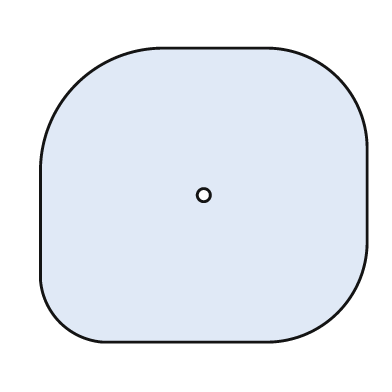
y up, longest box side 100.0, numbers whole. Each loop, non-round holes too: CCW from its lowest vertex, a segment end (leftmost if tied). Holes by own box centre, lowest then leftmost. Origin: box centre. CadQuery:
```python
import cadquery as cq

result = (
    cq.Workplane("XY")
    .moveTo(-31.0, -45.0)
    .lineTo(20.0, -45.0)
    .threePointArc((41.0, -36.0), (50.0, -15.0))
    .lineTo(50.0, 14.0)
    .threePointArc((41.0, 36.0), (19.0, 45.0))
    .lineTo(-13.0, 45.0)
    .threePointArc((-39.0, 34.0), (-50.0, 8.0))
    .lineTo(-50.0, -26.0)
    .threePointArc((-44.0, -39.0), (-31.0, -45.0))
    .close()
    .moveTo(0.0, 0.0)
    .circle(2.0)
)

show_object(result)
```